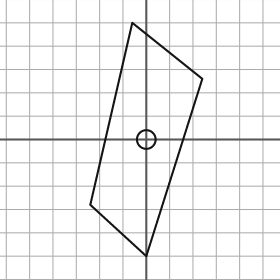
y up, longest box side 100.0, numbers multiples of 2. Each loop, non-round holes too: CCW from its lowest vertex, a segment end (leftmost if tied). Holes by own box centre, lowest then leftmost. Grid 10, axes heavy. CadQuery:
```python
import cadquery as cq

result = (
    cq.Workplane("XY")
    .moveTo(0.0, -50.0)
    .lineTo(24.0, 26.0)
    .lineTo(-6.0, 50.0)
    .lineTo(-24.0, -28.0)
    .close()
    .moveTo(0.0, 0.0)
    .circle(4.0)
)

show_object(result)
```